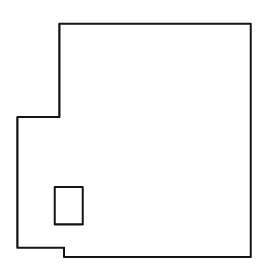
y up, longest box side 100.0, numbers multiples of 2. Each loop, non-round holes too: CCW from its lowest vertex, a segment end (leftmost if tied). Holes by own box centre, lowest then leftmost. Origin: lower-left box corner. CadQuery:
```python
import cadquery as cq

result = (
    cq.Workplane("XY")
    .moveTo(20.0, 0.0)
    .lineTo(100.0, 0.0)
    .lineTo(100.0, 100.0)
    .lineTo(18.0, 100.0)
    .lineTo(18.0, 60.0)
    .lineTo(0.0, 60.0)
    .lineTo(0.0, 4.0)
    .lineTo(20.0, 4.0)
    .close()
    .moveTo(16.0, 14.0)
    .lineTo(28.0, 14.0)
    .lineTo(28.0, 30.0)
    .lineTo(16.0, 30.0)
    .close()
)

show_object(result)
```